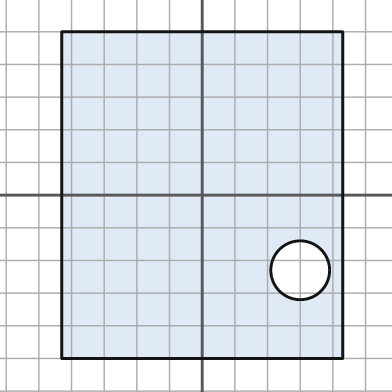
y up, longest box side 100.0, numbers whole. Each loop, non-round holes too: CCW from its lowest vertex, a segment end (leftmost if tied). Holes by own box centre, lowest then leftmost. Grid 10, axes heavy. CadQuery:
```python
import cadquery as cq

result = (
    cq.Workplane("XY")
    .moveTo(-43.0, -50.0)
    .lineTo(43.0, -50.0)
    .lineTo(43.0, 50.0)
    .lineTo(-43.0, 50.0)
    .close()
    .moveTo(30.0, -23.0)
    .circle(9.0)
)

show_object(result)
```